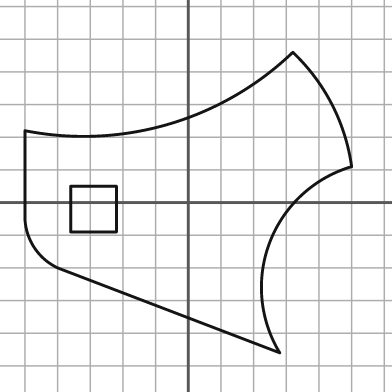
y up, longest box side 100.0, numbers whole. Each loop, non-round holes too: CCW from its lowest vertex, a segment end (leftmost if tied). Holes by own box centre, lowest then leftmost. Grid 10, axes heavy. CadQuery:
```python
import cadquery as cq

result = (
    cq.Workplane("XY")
    .moveTo(28.0, -46.0)
    .threePointArc((25.0, -12.0), (50.0, 11.0))
    .threePointArc((44.0, 30.0), (32.0, 46.0))
    .threePointArc((-6.0, 24.0), (-50.0, 22.0))
    .lineTo(-50.0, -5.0)
    .threePointArc((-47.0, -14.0), (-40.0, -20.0))
    .close()
    .moveTo(-36.0, -9.0)
    .lineTo(-22.0, -9.0)
    .lineTo(-22.0, 5.0)
    .lineTo(-36.0, 5.0)
    .close()
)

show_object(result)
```